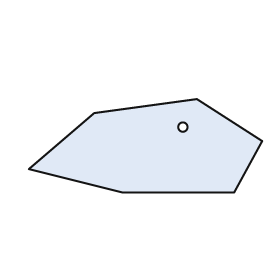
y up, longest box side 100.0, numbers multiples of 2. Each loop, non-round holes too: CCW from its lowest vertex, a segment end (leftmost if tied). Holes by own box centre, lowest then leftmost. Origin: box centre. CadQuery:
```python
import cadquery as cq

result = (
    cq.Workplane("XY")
    .moveTo(-10.0, -20.0)
    .lineTo(38.0, -20.0)
    .lineTo(50.0, 2.0)
    .lineTo(22.0, 20.0)
    .lineTo(-22.0, 14.0)
    .lineTo(-50.0, -10.0)
    .close()
    .moveTo(16.0, 8.0)
    .circle(2.0)
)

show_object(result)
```